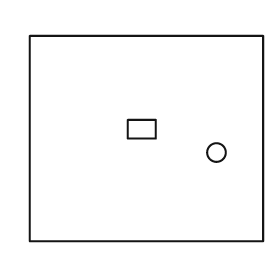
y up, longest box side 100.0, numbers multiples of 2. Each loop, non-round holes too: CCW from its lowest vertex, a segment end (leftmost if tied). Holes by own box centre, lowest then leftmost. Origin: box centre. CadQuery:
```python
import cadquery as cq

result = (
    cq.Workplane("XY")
    .moveTo(-50.0, -44.0)
    .lineTo(50.0, -44.0)
    .lineTo(50.0, 44.0)
    .lineTo(-50.0, 44.0)
    .close()
    .moveTo(30.0, -6.0)
    .circle(4.0)
    .moveTo(-8.0, 0.0)
    .lineTo(4.0, 0.0)
    .lineTo(4.0, 8.0)
    .lineTo(-8.0, 8.0)
    .close()
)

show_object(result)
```